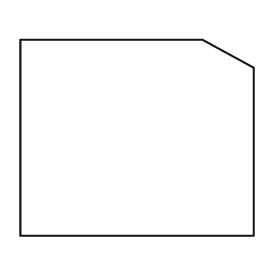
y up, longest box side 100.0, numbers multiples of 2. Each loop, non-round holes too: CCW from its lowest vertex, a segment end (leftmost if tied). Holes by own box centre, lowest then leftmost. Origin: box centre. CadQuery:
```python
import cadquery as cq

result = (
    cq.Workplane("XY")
    .moveTo(-50.0, -42.0)
    .lineTo(50.0, -42.0)
    .lineTo(50.0, 30.0)
    .lineTo(28.0, 42.0)
    .lineTo(-50.0, 42.0)
    .close()
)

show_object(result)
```